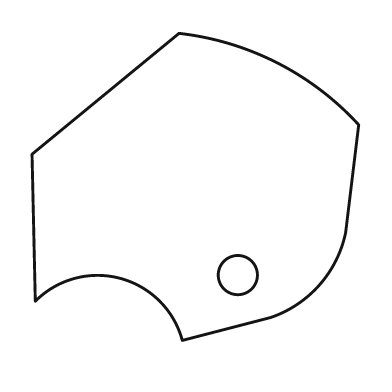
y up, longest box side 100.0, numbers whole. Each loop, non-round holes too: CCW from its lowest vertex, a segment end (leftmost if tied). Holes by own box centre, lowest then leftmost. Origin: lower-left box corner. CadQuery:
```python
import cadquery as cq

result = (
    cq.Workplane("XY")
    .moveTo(46.0, 0.0)
    .lineTo(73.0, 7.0)
    .threePointArc((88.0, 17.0), (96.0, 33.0))
    .lineTo(100.0, 66.0)
    .threePointArc((75.0, 85.0), (45.0, 94.0))
    .lineTo(0.0, 57.0)
    .lineTo(1.0, 12.0)
    .threePointArc((27.0, 19.0), (46.0, 0.0))
    .close()
    .moveTo(63.0, 20.0)
    .circle(6.0)
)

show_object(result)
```